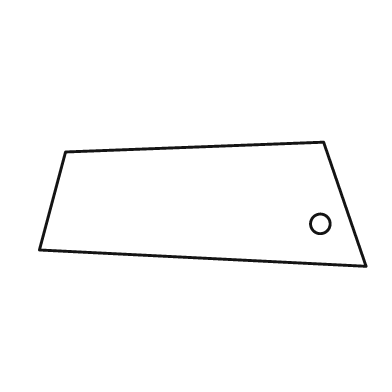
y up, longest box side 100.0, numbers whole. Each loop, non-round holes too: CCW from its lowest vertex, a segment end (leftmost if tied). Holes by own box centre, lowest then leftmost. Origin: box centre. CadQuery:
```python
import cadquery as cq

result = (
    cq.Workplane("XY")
    .moveTo(50.0, -19.0)
    .lineTo(37.0, 19.0)
    .lineTo(-42.0, 16.0)
    .lineTo(-50.0, -14.0)
    .close()
    .moveTo(36.0, -6.0)
    .circle(3.0)
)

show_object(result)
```